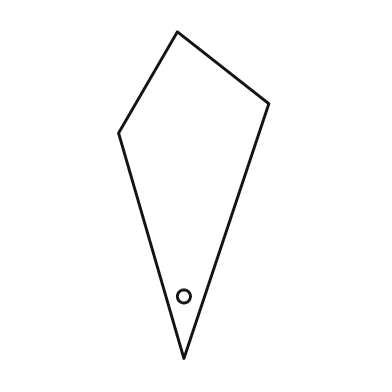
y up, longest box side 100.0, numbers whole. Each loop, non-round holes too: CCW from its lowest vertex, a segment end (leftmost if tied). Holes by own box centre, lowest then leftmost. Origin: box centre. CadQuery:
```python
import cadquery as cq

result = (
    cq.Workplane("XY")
    .moveTo(-3.0, -50.0)
    .lineTo(23.0, 28.0)
    .lineTo(-5.0, 50.0)
    .lineTo(-23.0, 19.0)
    .close()
    .moveTo(-3.0, -31.0)
    .circle(2.0)
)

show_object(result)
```